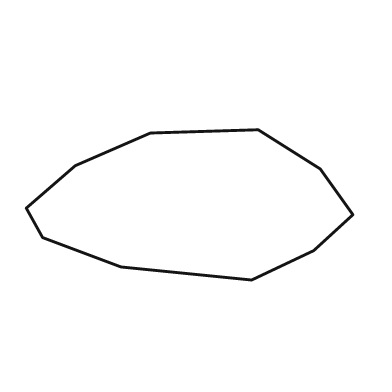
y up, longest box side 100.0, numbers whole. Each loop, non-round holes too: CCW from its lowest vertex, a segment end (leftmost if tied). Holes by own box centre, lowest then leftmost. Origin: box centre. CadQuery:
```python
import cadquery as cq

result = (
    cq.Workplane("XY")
    .moveTo(19.0, -23.0)
    .lineTo(38.0, -14.0)
    .lineTo(50.0, -3.0)
    .lineTo(40.0, 11.0)
    .lineTo(21.0, 23.0)
    .lineTo(-12.0, 22.0)
    .lineTo(-35.0, 12.0)
    .lineTo(-50.0, -1.0)
    .lineTo(-45.0, -10.0)
    .lineTo(-21.0, -19.0)
    .close()
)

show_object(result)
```